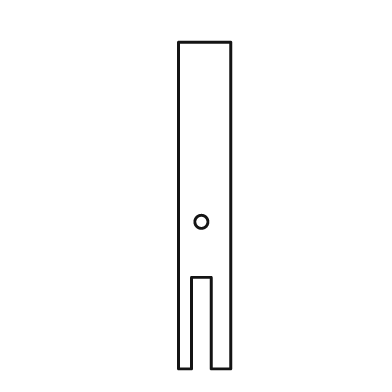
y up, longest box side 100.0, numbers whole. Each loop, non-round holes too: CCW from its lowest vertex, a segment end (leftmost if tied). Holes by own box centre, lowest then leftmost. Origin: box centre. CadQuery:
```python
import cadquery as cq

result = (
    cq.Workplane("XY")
    .moveTo(-8.0, -50.0)
    .lineTo(-4.0, -50.0)
    .lineTo(-4.0, -22.0)
    .lineTo(2.0, -22.0)
    .lineTo(2.0, -50.0)
    .lineTo(8.0, -50.0)
    .lineTo(8.0, 50.0)
    .lineTo(-8.0, 50.0)
    .close()
    .moveTo(-1.0, -5.0)
    .circle(2.0)
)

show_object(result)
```